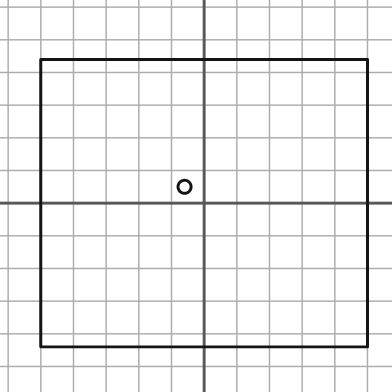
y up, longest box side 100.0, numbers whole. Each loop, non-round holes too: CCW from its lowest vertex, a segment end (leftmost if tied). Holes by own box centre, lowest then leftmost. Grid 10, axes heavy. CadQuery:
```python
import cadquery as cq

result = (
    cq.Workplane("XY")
    .moveTo(-50.0, -44.0)
    .lineTo(50.0, -44.0)
    .lineTo(50.0, 44.0)
    .lineTo(-50.0, 44.0)
    .close()
    .moveTo(-6.0, 5.0)
    .circle(2.0)
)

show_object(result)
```